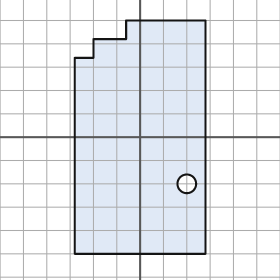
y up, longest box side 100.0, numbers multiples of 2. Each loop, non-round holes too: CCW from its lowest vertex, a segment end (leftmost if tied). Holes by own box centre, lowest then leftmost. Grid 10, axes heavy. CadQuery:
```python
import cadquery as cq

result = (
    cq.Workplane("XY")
    .moveTo(-28.0, -50.0)
    .lineTo(28.0, -50.0)
    .lineTo(28.0, 50.0)
    .lineTo(-6.0, 50.0)
    .lineTo(-6.0, 42.0)
    .lineTo(-20.0, 42.0)
    .lineTo(-20.0, 34.0)
    .lineTo(-28.0, 34.0)
    .close()
    .moveTo(20.0, -20.0)
    .circle(4.0)
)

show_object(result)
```